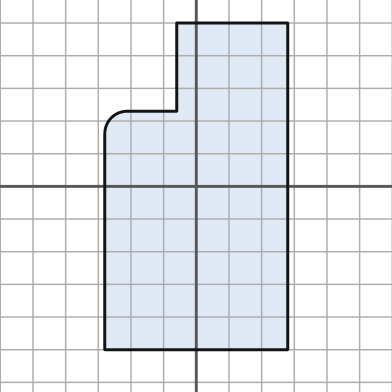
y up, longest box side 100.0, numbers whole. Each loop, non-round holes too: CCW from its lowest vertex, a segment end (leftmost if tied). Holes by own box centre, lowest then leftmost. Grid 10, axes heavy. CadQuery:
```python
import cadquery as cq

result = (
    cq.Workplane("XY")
    .moveTo(-28.0, -50.0)
    .lineTo(28.0, -50.0)
    .lineTo(28.0, 50.0)
    .lineTo(-6.0, 50.0)
    .lineTo(-6.0, 23.0)
    .lineTo(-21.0, 23.0)
    .threePointArc((-26.0, 21.0), (-28.0, 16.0))
    .close()
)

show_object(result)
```